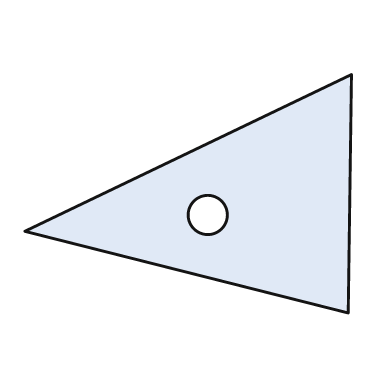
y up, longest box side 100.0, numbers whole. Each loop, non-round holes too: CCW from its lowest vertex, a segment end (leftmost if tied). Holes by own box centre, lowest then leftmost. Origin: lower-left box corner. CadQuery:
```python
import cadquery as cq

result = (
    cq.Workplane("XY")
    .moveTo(99.0, 0.0)
    .lineTo(100.0, 73.0)
    .lineTo(0.0, 25.0)
    .close()
    .moveTo(56.0, 30.0)
    .circle(6.0)
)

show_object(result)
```